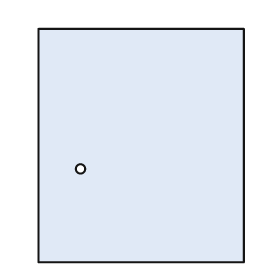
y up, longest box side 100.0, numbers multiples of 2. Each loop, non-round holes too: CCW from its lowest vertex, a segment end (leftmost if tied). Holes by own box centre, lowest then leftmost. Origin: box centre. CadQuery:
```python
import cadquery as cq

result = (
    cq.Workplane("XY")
    .moveTo(-44.0, -50.0)
    .lineTo(44.0, -50.0)
    .lineTo(44.0, 50.0)
    .lineTo(-44.0, 50.0)
    .close()
    .moveTo(-26.0, -10.0)
    .circle(2.0)
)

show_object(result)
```